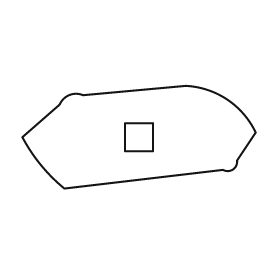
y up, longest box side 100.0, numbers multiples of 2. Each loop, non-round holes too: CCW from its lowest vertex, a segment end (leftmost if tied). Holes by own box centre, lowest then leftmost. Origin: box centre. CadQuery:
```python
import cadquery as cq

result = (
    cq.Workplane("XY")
    .moveTo(-32.0, -22.0)
    .lineTo(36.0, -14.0)
    .threePointArc((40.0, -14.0), (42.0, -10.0))
    .lineTo(50.0, 2.0)
    .threePointArc((38.0, 16.0), (20.0, 22.0))
    .lineTo(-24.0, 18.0)
    .threePointArc((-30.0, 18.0), (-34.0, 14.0))
    .lineTo(-50.0, 0.0)
    .threePointArc((-42.0, -12.0), (-32.0, -22.0))
    .close()
    .moveTo(-6.0, -6.0)
    .lineTo(6.0, -6.0)
    .lineTo(6.0, 6.0)
    .lineTo(-6.0, 6.0)
    .close()
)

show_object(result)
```